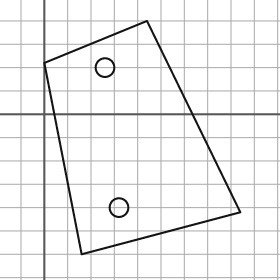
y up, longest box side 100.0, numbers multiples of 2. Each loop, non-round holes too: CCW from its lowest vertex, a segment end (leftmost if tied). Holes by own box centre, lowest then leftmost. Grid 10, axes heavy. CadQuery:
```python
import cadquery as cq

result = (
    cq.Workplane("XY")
    .moveTo(16.0, -60.0)
    .lineTo(84.0, -42.0)
    .lineTo(44.0, 40.0)
    .lineTo(0.0, 22.0)
    .close()
    .moveTo(32.0, -40.0)
    .circle(4.0)
    .moveTo(26.0, 20.0)
    .circle(4.0)
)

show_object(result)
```